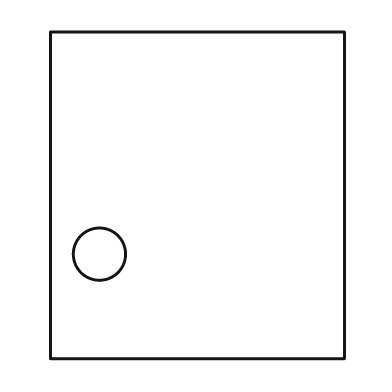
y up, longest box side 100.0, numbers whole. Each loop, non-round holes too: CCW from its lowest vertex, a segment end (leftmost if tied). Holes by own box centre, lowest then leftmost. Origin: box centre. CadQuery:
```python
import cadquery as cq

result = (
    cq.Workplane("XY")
    .moveTo(-45.0, -50.0)
    .lineTo(45.0, -50.0)
    .lineTo(45.0, 50.0)
    .lineTo(-45.0, 50.0)
    .close()
    .moveTo(-30.0, -18.0)
    .circle(8.0)
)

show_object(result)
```